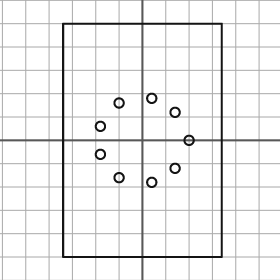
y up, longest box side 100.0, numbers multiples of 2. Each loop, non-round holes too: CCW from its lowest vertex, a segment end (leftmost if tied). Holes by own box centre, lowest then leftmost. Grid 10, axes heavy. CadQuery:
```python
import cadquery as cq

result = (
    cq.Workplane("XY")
    .moveTo(-34.0, -50.0)
    .lineTo(34.0, -50.0)
    .lineTo(34.0, 50.0)
    .lineTo(-34.0, 50.0)
    .close()
    .moveTo(4.0, -18.0)
    .circle(2.0)
    .moveTo(-10.0, -16.0)
    .circle(2.0)
    .moveTo(14.0, -12.0)
    .circle(2.0)
    .moveTo(-18.0, -6.0)
    .circle(2.0)
    .moveTo(20.0, 0.0)
    .circle(2.0)
    .moveTo(-18.0, 6.0)
    .circle(2.0)
    .moveTo(14.0, 12.0)
    .circle(2.0)
    .moveTo(-10.0, 16.0)
    .circle(2.0)
    .moveTo(4.0, 18.0)
    .circle(2.0)
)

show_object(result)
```